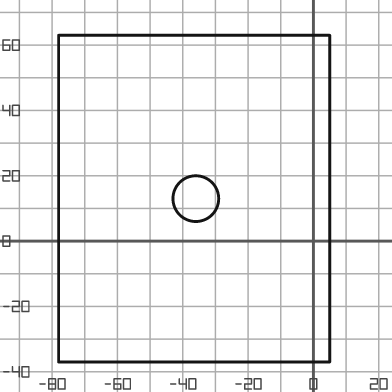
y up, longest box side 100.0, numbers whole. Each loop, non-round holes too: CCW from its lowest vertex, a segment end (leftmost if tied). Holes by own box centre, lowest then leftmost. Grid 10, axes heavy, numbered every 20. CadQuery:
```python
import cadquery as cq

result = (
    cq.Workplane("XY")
    .moveTo(-78.0, -37.0)
    .lineTo(5.0, -37.0)
    .lineTo(5.0, 63.0)
    .lineTo(-78.0, 63.0)
    .close()
    .moveTo(-36.0, 13.0)
    .circle(7.0)
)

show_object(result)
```